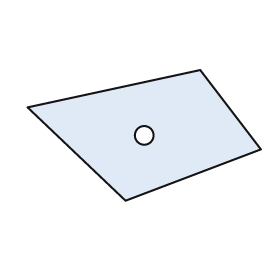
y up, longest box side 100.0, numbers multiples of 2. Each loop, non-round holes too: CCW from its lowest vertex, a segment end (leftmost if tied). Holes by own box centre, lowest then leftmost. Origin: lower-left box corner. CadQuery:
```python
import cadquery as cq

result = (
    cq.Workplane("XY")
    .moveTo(42.0, 0.0)
    .lineTo(100.0, 22.0)
    .lineTo(74.0, 56.0)
    .lineTo(0.0, 40.0)
    .close()
    .moveTo(50.0, 28.0)
    .circle(4.0)
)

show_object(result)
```